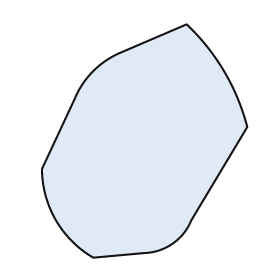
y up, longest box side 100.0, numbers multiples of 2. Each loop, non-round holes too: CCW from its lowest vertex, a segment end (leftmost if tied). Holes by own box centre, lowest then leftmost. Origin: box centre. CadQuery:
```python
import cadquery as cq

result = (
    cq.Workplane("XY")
    .moveTo(-22.0, -50.0)
    .lineTo(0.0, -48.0)
    .threePointArc((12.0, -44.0), (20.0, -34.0))
    .lineTo(44.0, 6.0)
    .threePointArc((34.0, 30.0), (18.0, 50.0))
    .lineTo(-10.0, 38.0)
    .threePointArc((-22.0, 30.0), (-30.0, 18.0))
    .lineTo(-44.0, -12.0)
    .threePointArc((-38.0, -34.0), (-22.0, -50.0))
    .close()
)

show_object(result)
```